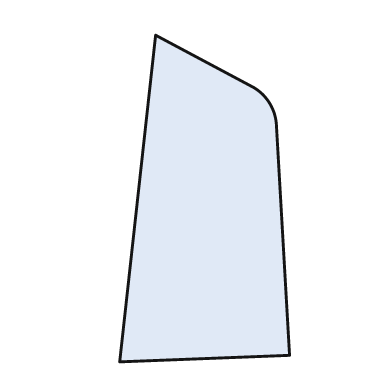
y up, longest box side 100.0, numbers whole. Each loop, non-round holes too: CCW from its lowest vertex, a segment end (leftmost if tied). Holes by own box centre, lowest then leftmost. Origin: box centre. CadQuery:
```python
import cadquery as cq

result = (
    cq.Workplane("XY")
    .moveTo(-26.0, -50.0)
    .lineTo(26.0, -48.0)
    .lineTo(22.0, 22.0)
    .threePointArc((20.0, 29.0), (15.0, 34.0))
    .lineTo(-15.0, 50.0)
    .close()
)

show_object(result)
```